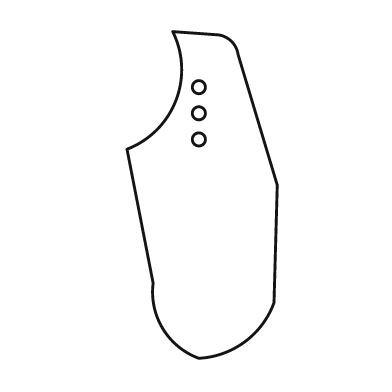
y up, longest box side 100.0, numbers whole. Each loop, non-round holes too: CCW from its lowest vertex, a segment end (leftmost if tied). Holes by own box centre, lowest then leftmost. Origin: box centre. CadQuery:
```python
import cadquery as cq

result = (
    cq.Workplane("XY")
    .moveTo(-1.0, -50.0)
    .threePointArc((13.0, -45.0), (22.0, -33.0))
    .lineTo(23.0, 3.0)
    .lineTo(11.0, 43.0)
    .threePointArc((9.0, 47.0), (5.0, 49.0))
    .lineTo(-9.0, 50.0)
    .threePointArc((-8.0, 29.0), (-23.0, 14.0))
    .lineTo(-15.0, -27.0)
    .threePointArc((-12.0, -41.0), (-1.0, -50.0))
    .close()
    .moveTo(-1.0, 17.0)
    .circle(2.0)
    .moveTo(-1.0, 25.0)
    .circle(2.0)
    .moveTo(-1.0, 33.0)
    .circle(2.0)
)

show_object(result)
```